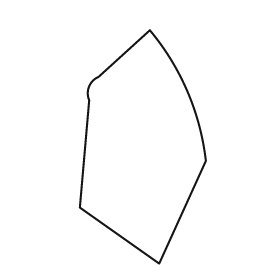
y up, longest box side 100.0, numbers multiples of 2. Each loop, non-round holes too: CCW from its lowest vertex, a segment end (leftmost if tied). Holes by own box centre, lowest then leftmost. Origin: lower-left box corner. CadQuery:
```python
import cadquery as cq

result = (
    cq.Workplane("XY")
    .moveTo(34.0, 0.0)
    .lineTo(54.0, 44.0)
    .threePointArc((46.0, 74.0), (30.0, 100.0))
    .lineTo(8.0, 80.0)
    .threePointArc((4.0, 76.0), (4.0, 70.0))
    .lineTo(0.0, 24.0)
    .close()
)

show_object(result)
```